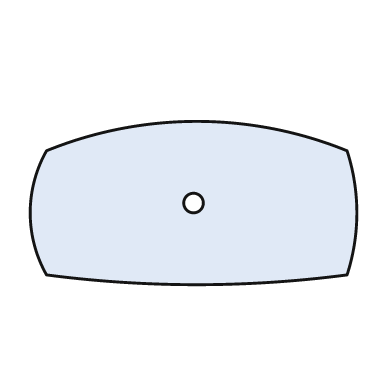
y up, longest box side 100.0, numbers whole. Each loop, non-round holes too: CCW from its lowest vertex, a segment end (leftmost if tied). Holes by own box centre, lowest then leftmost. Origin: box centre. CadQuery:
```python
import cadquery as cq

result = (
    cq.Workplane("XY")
    .moveTo(-45.0, -22.0)
    .threePointArc((1.0, -25.0), (47.0, -22.0))
    .threePointArc((50.0, -3.0), (47.0, 16.0))
    .threePointArc((1.0, 25.0), (-45.0, 16.0))
    .threePointArc((-50.0, -3.0), (-45.0, -22.0))
    .close()
    .moveTo(0.0, 0.0)
    .circle(3.0)
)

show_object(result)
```